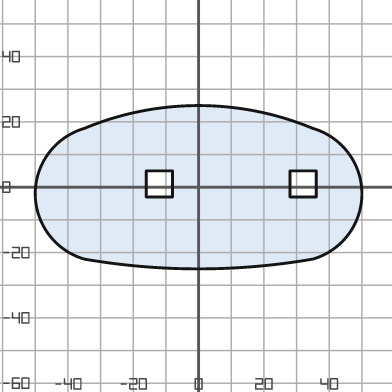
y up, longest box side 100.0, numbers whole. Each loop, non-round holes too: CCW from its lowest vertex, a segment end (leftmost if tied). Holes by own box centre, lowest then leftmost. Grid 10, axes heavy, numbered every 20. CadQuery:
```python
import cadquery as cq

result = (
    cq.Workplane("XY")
    .moveTo(-35.0, -22.0)
    .threePointArc((0.0, -25.0), (35.0, -22.0))
    .threePointArc((50.0, -2.0), (35.0, 18.0))
    .threePointArc((0.0, 25.0), (-35.0, 18.0))
    .threePointArc((-50.0, -2.0), (-35.0, -22.0))
    .close()
    .moveTo(-16.0, -3.0)
    .lineTo(-8.0, -3.0)
    .lineTo(-8.0, 5.0)
    .lineTo(-16.0, 5.0)
    .close()
    .moveTo(28.0, -3.0)
    .lineTo(36.0, -3.0)
    .lineTo(36.0, 5.0)
    .lineTo(28.0, 5.0)
    .close()
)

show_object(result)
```